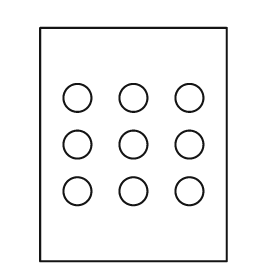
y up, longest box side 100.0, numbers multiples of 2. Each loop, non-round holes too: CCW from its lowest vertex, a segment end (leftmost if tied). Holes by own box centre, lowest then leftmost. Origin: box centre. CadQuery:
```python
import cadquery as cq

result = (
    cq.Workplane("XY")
    .moveTo(-40.0, -50.0)
    .lineTo(40.0, -50.0)
    .lineTo(40.0, 50.0)
    .lineTo(-40.0, 50.0)
    .close()
    .moveTo(-24.0, -20.0)
    .circle(6.0)
    .moveTo(0.0, -20.0)
    .circle(6.0)
    .moveTo(24.0, -20.0)
    .circle(6.0)
    .moveTo(-24.0, 0.0)
    .circle(6.0)
    .moveTo(0.0, 0.0)
    .circle(6.0)
    .moveTo(24.0, 0.0)
    .circle(6.0)
    .moveTo(-24.0, 20.0)
    .circle(6.0)
    .moveTo(0.0, 20.0)
    .circle(6.0)
    .moveTo(24.0, 20.0)
    .circle(6.0)
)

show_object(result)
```